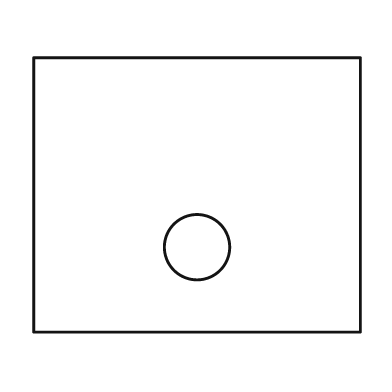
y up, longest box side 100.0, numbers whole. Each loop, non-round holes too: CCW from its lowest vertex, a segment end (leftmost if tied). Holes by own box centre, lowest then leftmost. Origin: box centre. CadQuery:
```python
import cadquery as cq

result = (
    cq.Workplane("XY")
    .moveTo(-50.0, -42.0)
    .lineTo(50.0, -42.0)
    .lineTo(50.0, 42.0)
    .lineTo(-50.0, 42.0)
    .close()
    .moveTo(0.0, -16.0)
    .circle(10.0)
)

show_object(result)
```